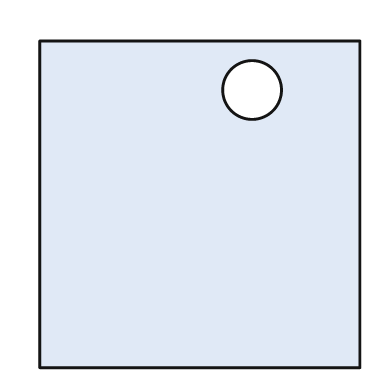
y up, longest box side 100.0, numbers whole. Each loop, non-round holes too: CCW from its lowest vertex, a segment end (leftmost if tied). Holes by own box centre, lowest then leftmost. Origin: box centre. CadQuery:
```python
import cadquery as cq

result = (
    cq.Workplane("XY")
    .moveTo(-49.0, -50.0)
    .lineTo(49.0, -50.0)
    .lineTo(49.0, 50.0)
    .lineTo(-49.0, 50.0)
    .close()
    .moveTo(16.0, 35.0)
    .circle(9.0)
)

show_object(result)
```